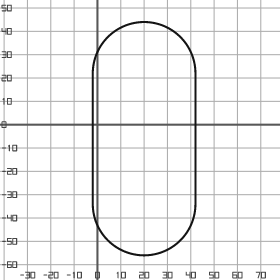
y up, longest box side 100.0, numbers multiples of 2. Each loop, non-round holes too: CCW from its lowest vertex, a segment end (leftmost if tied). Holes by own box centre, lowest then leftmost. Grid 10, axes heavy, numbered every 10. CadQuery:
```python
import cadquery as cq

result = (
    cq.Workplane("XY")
    .moveTo(-2.0, -34.0)
    .threePointArc((20.0, -56.0), (42.0, -34.0))
    .lineTo(42.0, 22.0)
    .threePointArc((20.0, 44.0), (-2.0, 22.0))
    .close()
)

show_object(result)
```